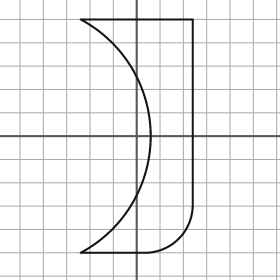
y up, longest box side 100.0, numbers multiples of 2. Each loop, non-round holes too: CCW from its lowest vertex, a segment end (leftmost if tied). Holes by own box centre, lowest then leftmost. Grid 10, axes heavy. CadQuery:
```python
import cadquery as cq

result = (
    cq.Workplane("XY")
    .moveTo(-24.0, -50.0)
    .lineTo(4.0, -50.0)
    .threePointArc((18.0, -44.0), (24.0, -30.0))
    .lineTo(24.0, 50.0)
    .lineTo(-24.0, 50.0)
    .threePointArc((6.0, 0.0), (-24.0, -50.0))
    .close()
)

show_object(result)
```